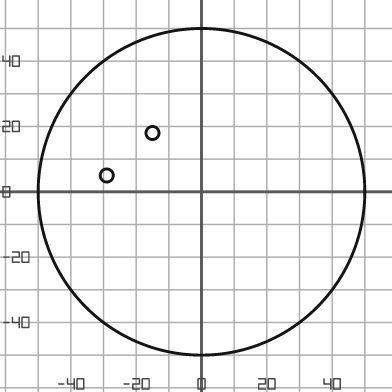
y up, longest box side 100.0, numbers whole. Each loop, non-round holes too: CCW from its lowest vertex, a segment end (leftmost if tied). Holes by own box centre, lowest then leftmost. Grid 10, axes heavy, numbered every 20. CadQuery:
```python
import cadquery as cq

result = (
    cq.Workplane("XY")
    .moveTo(0.0, 0.0)
    .circle(50.0)
    .moveTo(-29.0, 5.0)
    .circle(2.0)
    .moveTo(-15.0, 18.0)
    .circle(2.0)
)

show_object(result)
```